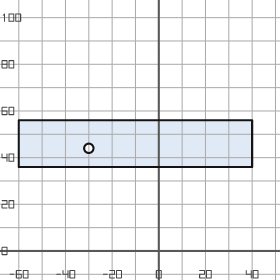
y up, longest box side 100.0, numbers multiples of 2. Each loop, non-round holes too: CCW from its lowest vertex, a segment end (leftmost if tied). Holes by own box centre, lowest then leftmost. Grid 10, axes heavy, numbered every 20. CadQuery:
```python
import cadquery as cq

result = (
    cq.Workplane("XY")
    .moveTo(-60.0, 36.0)
    .lineTo(40.0, 36.0)
    .lineTo(40.0, 56.0)
    .lineTo(-60.0, 56.0)
    .close()
    .moveTo(-30.0, 44.0)
    .circle(2.0)
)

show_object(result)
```